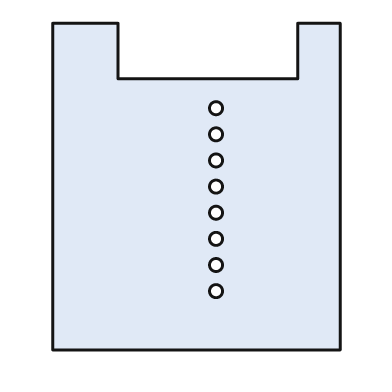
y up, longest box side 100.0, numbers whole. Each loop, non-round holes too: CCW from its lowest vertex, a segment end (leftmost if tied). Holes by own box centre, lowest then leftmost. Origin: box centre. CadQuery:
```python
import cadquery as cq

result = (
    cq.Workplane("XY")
    .moveTo(-44.0, -50.0)
    .lineTo(44.0, -50.0)
    .lineTo(44.0, 50.0)
    .lineTo(31.0, 50.0)
    .lineTo(31.0, 33.0)
    .lineTo(-24.0, 33.0)
    .lineTo(-24.0, 50.0)
    .lineTo(-44.0, 50.0)
    .close()
    .moveTo(6.0, -32.0)
    .circle(2.0)
    .moveTo(6.0, -24.0)
    .circle(2.0)
    .moveTo(6.0, -16.0)
    .circle(2.0)
    .moveTo(6.0, -8.0)
    .circle(2.0)
    .moveTo(6.0, 0.0)
    .circle(2.0)
    .moveTo(6.0, 8.0)
    .circle(2.0)
    .moveTo(6.0, 16.0)
    .circle(2.0)
    .moveTo(6.0, 24.0)
    .circle(2.0)
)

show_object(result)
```